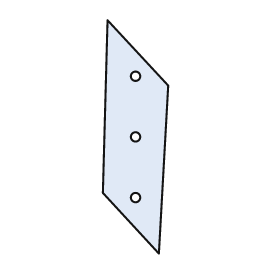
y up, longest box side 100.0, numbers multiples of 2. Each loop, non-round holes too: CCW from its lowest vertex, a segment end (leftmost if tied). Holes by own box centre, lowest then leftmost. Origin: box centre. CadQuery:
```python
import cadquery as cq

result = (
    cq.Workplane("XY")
    .moveTo(10.0, -50.0)
    .lineTo(14.0, 22.0)
    .lineTo(-12.0, 50.0)
    .lineTo(-14.0, -24.0)
    .close()
    .moveTo(0.0, -26.0)
    .circle(2.0)
    .moveTo(0.0, 0.0)
    .circle(2.0)
    .moveTo(0.0, 26.0)
    .circle(2.0)
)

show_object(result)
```